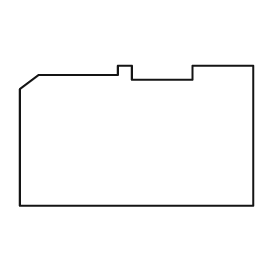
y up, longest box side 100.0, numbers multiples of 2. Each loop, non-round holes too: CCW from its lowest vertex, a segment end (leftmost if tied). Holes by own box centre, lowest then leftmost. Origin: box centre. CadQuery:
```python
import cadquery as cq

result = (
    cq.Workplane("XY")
    .moveTo(-50.0, -30.0)
    .lineTo(50.0, -30.0)
    .lineTo(50.0, 30.0)
    .lineTo(24.0, 30.0)
    .lineTo(24.0, 24.0)
    .lineTo(-2.0, 24.0)
    .lineTo(-2.0, 30.0)
    .lineTo(-8.0, 30.0)
    .lineTo(-8.0, 26.0)
    .lineTo(-42.0, 26.0)
    .lineTo(-50.0, 20.0)
    .close()
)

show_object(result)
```